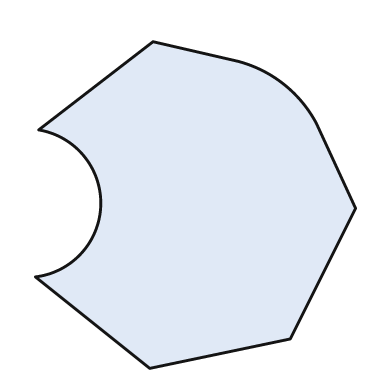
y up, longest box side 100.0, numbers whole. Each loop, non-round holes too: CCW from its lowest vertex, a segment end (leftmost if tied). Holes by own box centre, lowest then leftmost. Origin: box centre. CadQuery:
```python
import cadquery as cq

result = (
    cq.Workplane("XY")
    .moveTo(-14.0, -50.0)
    .lineTo(29.0, -41.0)
    .lineTo(49.0, -1.0)
    .lineTo(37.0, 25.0)
    .threePointArc((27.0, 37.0), (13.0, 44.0))
    .lineTo(-13.0, 50.0)
    .lineTo(-48.0, 23.0)
    .threePointArc((-29.0, 0.0), (-49.0, -22.0))
    .close()
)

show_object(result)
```